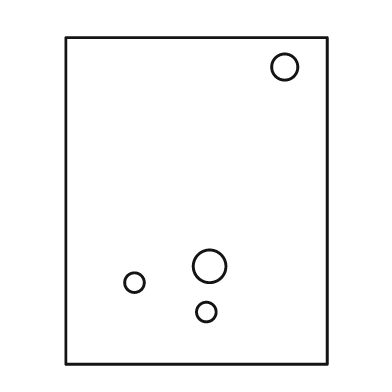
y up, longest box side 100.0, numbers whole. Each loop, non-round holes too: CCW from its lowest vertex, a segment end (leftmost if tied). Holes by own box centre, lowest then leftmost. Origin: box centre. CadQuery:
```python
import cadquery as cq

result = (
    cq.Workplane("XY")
    .moveTo(-40.0, -50.0)
    .lineTo(40.0, -50.0)
    .lineTo(40.0, 50.0)
    .lineTo(-40.0, 50.0)
    .close()
    .moveTo(3.0, -34.0)
    .circle(3.0)
    .moveTo(-19.0, -25.0)
    .circle(3.0)
    .moveTo(4.0, -20.0)
    .circle(5.0)
    .moveTo(27.0, 41.0)
    .circle(4.0)
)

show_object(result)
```